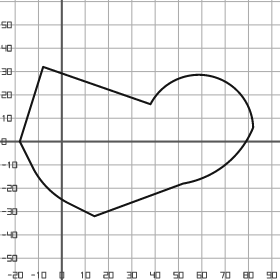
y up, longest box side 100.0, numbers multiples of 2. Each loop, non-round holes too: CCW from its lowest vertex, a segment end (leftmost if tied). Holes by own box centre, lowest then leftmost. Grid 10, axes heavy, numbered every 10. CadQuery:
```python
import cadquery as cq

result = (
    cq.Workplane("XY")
    .moveTo(14.0, -32.0)
    .lineTo(52.0, -18.0)
    .threePointArc((70.0, -10.0), (82.0, 6.0))
    .threePointArc((64.0, 28.0), (38.0, 16.0))
    .lineTo(-8.0, 32.0)
    .lineTo(-18.0, 0.0)
    .lineTo(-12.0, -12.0)
    .threePointArc((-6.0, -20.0), (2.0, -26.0))
    .close()
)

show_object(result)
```